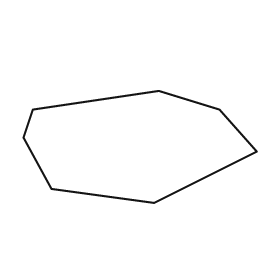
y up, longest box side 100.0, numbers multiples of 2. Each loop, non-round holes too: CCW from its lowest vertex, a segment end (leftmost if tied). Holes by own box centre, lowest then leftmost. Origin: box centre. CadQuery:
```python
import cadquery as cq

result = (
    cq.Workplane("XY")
    .moveTo(6.0, -24.0)
    .lineTo(50.0, -2.0)
    .lineTo(34.0, 16.0)
    .lineTo(8.0, 24.0)
    .lineTo(-46.0, 16.0)
    .lineTo(-50.0, 4.0)
    .lineTo(-38.0, -18.0)
    .close()
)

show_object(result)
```